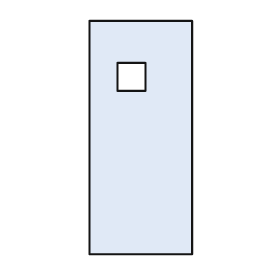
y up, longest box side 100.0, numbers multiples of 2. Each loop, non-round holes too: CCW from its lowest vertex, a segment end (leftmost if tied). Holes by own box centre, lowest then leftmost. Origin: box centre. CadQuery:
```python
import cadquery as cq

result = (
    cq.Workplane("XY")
    .moveTo(-22.0, -50.0)
    .lineTo(22.0, -50.0)
    .lineTo(22.0, 50.0)
    .lineTo(-22.0, 50.0)
    .close()
    .moveTo(-10.0, 20.0)
    .lineTo(2.0, 20.0)
    .lineTo(2.0, 32.0)
    .lineTo(-10.0, 32.0)
    .close()
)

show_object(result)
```